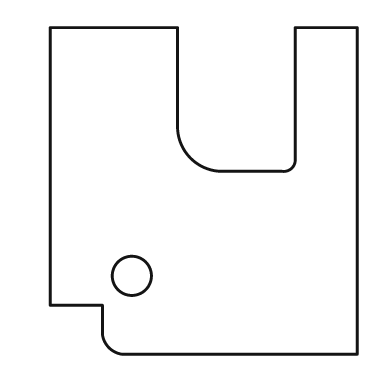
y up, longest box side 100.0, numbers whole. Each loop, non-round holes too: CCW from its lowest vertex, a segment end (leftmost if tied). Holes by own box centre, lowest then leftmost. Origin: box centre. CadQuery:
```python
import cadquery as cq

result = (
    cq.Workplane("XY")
    .moveTo(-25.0, -50.0)
    .lineTo(47.0, -50.0)
    .lineTo(47.0, 50.0)
    .lineTo(28.0, 50.0)
    .lineTo(28.0, 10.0)
    .threePointArc((27.0, 7.0), (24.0, 6.0))
    .lineTo(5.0, 6.0)
    .threePointArc((-4.0, 10.0), (-8.0, 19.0))
    .lineTo(-8.0, 50.0)
    .lineTo(-47.0, 50.0)
    .lineTo(-47.0, -35.0)
    .lineTo(-31.0, -35.0)
    .lineTo(-31.0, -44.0)
    .threePointArc((-29.0, -48.0), (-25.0, -50.0))
    .close()
    .moveTo(-22.0, -26.0)
    .circle(6.0)
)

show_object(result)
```